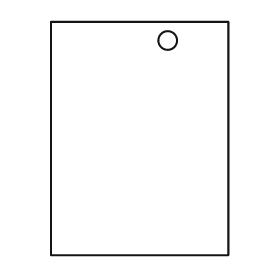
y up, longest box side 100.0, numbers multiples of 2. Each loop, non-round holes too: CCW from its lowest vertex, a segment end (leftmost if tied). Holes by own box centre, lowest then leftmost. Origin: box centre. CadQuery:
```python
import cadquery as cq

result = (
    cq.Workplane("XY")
    .moveTo(-38.0, -50.0)
    .lineTo(38.0, -50.0)
    .lineTo(38.0, 50.0)
    .lineTo(-38.0, 50.0)
    .close()
    .moveTo(12.0, 42.0)
    .circle(4.0)
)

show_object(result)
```